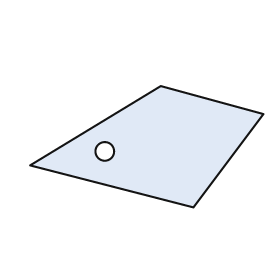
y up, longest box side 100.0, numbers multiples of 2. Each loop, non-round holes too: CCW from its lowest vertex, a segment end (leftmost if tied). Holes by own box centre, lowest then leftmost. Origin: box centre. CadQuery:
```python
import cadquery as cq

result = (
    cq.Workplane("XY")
    .moveTo(20.0, -26.0)
    .lineTo(50.0, 14.0)
    .lineTo(6.0, 26.0)
    .lineTo(-50.0, -8.0)
    .close()
    .moveTo(-18.0, -2.0)
    .circle(4.0)
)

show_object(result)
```